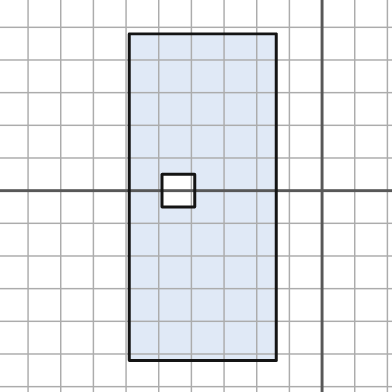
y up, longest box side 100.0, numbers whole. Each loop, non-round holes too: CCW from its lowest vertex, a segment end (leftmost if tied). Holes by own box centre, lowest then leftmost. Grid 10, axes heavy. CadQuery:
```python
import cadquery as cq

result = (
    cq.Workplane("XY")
    .moveTo(-59.0, -52.0)
    .lineTo(-14.0, -52.0)
    .lineTo(-14.0, 48.0)
    .lineTo(-59.0, 48.0)
    .close()
    .moveTo(-49.0, -5.0)
    .lineTo(-39.0, -5.0)
    .lineTo(-39.0, 5.0)
    .lineTo(-49.0, 5.0)
    .close()
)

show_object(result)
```